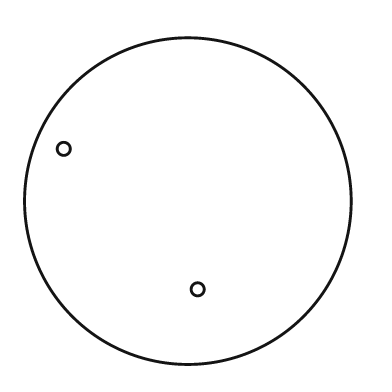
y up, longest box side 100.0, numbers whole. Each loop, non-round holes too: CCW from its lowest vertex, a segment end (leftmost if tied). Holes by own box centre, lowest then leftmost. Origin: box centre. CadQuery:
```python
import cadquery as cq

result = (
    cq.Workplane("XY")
    .moveTo(0.0, 0.0)
    .circle(50.0)
    .moveTo(3.0, -27.0)
    .circle(2.0)
    .moveTo(-38.0, 16.0)
    .circle(2.0)
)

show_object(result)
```